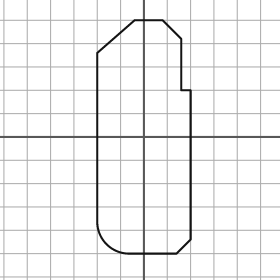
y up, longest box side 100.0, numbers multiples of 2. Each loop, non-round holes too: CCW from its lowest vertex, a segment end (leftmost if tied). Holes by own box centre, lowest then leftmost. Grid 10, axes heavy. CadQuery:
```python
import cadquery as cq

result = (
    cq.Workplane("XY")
    .moveTo(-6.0, -50.0)
    .lineTo(14.0, -50.0)
    .lineTo(20.0, -44.0)
    .lineTo(20.0, 20.0)
    .lineTo(16.0, 20.0)
    .lineTo(16.0, 42.0)
    .lineTo(8.0, 50.0)
    .lineTo(-4.0, 50.0)
    .lineTo(-20.0, 36.0)
    .lineTo(-20.0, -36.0)
    .threePointArc((-16.0, -46.0), (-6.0, -50.0))
    .close()
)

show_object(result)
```